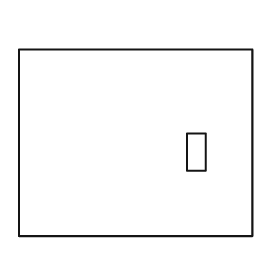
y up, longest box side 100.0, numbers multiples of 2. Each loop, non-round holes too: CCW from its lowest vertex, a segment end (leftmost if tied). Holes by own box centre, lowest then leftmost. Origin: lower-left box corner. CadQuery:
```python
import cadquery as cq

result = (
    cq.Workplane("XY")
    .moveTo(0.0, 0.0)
    .lineTo(100.0, 0.0)
    .lineTo(100.0, 80.0)
    .lineTo(0.0, 80.0)
    .close()
    .moveTo(72.0, 28.0)
    .lineTo(80.0, 28.0)
    .lineTo(80.0, 44.0)
    .lineTo(72.0, 44.0)
    .close()
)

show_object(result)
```